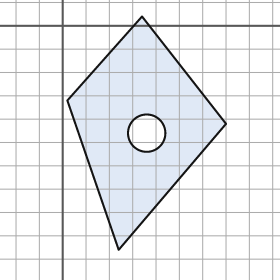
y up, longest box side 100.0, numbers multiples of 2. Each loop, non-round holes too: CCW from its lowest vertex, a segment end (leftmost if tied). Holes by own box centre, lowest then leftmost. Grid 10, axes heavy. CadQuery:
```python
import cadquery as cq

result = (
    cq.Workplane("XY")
    .moveTo(24.0, -96.0)
    .lineTo(70.0, -42.0)
    .lineTo(34.0, 4.0)
    .lineTo(2.0, -32.0)
    .close()
    .moveTo(36.0, -46.0)
    .circle(8.0)
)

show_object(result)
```